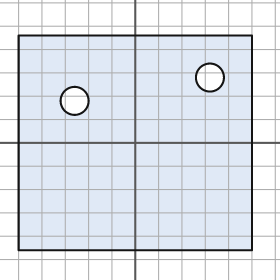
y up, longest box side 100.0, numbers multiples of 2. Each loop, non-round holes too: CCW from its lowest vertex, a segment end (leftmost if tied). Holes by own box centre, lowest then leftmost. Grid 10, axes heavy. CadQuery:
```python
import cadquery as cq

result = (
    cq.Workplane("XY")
    .moveTo(-50.0, -46.0)
    .lineTo(50.0, -46.0)
    .lineTo(50.0, 46.0)
    .lineTo(-50.0, 46.0)
    .close()
    .moveTo(-26.0, 18.0)
    .circle(6.0)
    .moveTo(32.0, 28.0)
    .circle(6.0)
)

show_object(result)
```